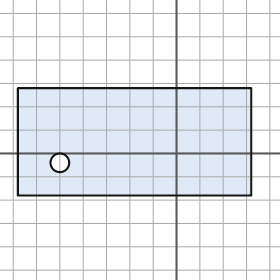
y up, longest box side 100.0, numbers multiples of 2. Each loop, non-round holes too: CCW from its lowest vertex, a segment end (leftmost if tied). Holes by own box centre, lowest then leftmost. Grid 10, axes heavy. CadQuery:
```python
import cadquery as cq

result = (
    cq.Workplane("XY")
    .moveTo(-68.0, -18.0)
    .lineTo(32.0, -18.0)
    .lineTo(32.0, 28.0)
    .lineTo(-68.0, 28.0)
    .close()
    .moveTo(-50.0, -4.0)
    .circle(4.0)
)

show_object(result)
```